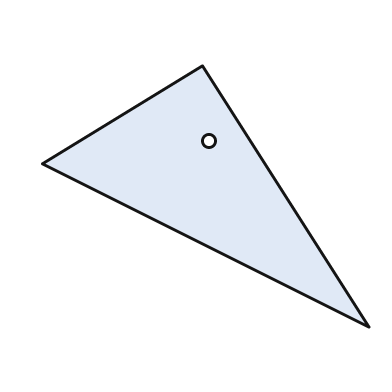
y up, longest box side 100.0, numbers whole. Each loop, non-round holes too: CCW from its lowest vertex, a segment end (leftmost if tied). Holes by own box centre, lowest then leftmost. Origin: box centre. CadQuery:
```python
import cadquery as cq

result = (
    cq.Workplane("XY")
    .moveTo(50.0, -40.0)
    .lineTo(-1.0, 40.0)
    .lineTo(-50.0, 10.0)
    .close()
    .moveTo(1.0, 17.0)
    .circle(2.0)
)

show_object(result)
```